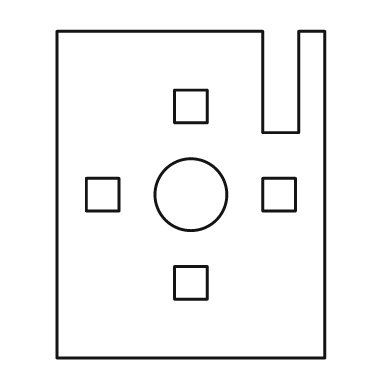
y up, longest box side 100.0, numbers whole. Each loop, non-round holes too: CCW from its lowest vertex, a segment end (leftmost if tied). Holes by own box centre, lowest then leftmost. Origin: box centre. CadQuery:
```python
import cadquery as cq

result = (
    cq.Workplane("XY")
    .moveTo(-41.0, -50.0)
    .lineTo(41.0, -50.0)
    .lineTo(41.0, 50.0)
    .lineTo(33.0, 50.0)
    .lineTo(33.0, 19.0)
    .lineTo(22.0, 19.0)
    .lineTo(22.0, 50.0)
    .lineTo(-41.0, 50.0)
    .close()
    .moveTo(-5.0, -32.0)
    .lineTo(5.0, -32.0)
    .lineTo(5.0, -22.0)
    .lineTo(-5.0, -22.0)
    .close()
    .moveTo(-32.0, -5.0)
    .lineTo(-22.0, -5.0)
    .lineTo(-22.0, 5.0)
    .lineTo(-32.0, 5.0)
    .close()
    .moveTo(0.0, 0.0)
    .circle(11.0)
    .moveTo(22.0, -5.0)
    .lineTo(32.0, -5.0)
    .lineTo(32.0, 5.0)
    .lineTo(22.0, 5.0)
    .close()
    .moveTo(-5.0, 22.0)
    .lineTo(5.0, 22.0)
    .lineTo(5.0, 32.0)
    .lineTo(-5.0, 32.0)
    .close()
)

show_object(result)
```